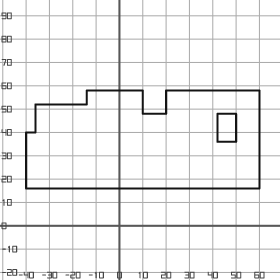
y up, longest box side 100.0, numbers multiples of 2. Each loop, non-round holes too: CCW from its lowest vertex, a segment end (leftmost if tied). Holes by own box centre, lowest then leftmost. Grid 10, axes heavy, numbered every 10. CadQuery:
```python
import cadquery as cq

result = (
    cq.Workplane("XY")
    .moveTo(-40.0, 16.0)
    .lineTo(60.0, 16.0)
    .lineTo(60.0, 58.0)
    .lineTo(20.0, 58.0)
    .lineTo(20.0, 48.0)
    .lineTo(10.0, 48.0)
    .lineTo(10.0, 58.0)
    .lineTo(-14.0, 58.0)
    .lineTo(-14.0, 52.0)
    .lineTo(-36.0, 52.0)
    .lineTo(-36.0, 40.0)
    .lineTo(-40.0, 40.0)
    .close()
    .moveTo(42.0, 36.0)
    .lineTo(50.0, 36.0)
    .lineTo(50.0, 48.0)
    .lineTo(42.0, 48.0)
    .close()
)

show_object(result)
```